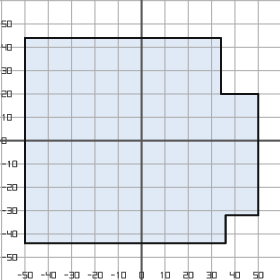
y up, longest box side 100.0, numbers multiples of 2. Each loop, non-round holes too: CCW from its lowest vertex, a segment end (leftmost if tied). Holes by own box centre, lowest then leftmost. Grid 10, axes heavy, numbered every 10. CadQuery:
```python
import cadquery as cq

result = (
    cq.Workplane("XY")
    .moveTo(-50.0, -44.0)
    .lineTo(36.0, -44.0)
    .lineTo(36.0, -32.0)
    .lineTo(50.0, -32.0)
    .lineTo(50.0, 20.0)
    .lineTo(34.0, 20.0)
    .lineTo(34.0, 44.0)
    .lineTo(-50.0, 44.0)
    .close()
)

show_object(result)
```